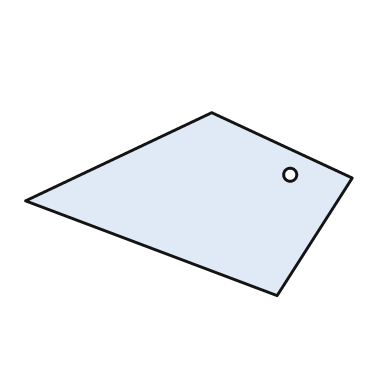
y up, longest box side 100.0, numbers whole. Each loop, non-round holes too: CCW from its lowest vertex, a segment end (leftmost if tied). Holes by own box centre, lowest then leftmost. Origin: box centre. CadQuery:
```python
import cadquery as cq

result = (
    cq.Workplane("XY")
    .moveTo(27.0, -28.0)
    .lineTo(50.0, 8.0)
    .lineTo(7.0, 28.0)
    .lineTo(-50.0, 1.0)
    .close()
    .moveTo(31.0, 9.0)
    .circle(2.0)
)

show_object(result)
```